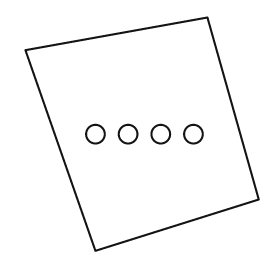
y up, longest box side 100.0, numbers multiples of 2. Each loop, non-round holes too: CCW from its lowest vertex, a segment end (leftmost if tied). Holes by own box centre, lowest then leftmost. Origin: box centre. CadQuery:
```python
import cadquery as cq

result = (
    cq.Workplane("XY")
    .moveTo(-20.0, -50.0)
    .lineTo(50.0, -28.0)
    .lineTo(28.0, 50.0)
    .lineTo(-50.0, 36.0)
    .close()
    .moveTo(-20.0, 0.0)
    .circle(4.0)
    .moveTo(-6.0, 0.0)
    .circle(4.0)
    .moveTo(8.0, 0.0)
    .circle(4.0)
    .moveTo(22.0, 0.0)
    .circle(4.0)
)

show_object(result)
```